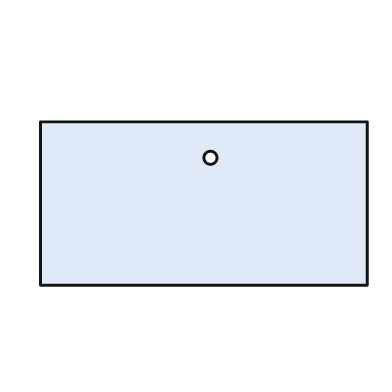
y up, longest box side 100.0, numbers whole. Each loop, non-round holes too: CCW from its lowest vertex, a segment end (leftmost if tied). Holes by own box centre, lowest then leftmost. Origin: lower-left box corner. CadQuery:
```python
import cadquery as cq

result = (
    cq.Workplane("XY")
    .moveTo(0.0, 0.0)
    .lineTo(100.0, 0.0)
    .lineTo(100.0, 50.0)
    .lineTo(0.0, 50.0)
    .close()
    .moveTo(52.0, 39.0)
    .circle(2.0)
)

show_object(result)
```